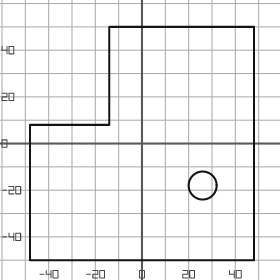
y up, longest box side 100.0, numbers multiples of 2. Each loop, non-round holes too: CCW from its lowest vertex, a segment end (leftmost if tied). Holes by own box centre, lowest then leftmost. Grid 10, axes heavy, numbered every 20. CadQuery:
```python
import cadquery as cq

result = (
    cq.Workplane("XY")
    .moveTo(-48.0, -50.0)
    .lineTo(48.0, -50.0)
    .lineTo(48.0, 50.0)
    .lineTo(-14.0, 50.0)
    .lineTo(-14.0, 8.0)
    .lineTo(-48.0, 8.0)
    .close()
    .moveTo(26.0, -18.0)
    .circle(6.0)
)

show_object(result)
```